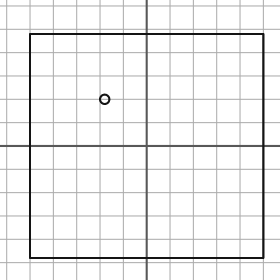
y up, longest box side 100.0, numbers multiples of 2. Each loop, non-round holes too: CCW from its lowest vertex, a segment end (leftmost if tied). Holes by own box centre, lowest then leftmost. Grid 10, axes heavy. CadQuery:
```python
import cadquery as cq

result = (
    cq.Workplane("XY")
    .moveTo(-50.0, -48.0)
    .lineTo(50.0, -48.0)
    .lineTo(50.0, 48.0)
    .lineTo(-50.0, 48.0)
    .close()
    .moveTo(-18.0, 20.0)
    .circle(2.0)
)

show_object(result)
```